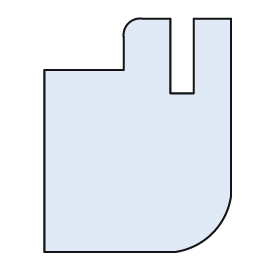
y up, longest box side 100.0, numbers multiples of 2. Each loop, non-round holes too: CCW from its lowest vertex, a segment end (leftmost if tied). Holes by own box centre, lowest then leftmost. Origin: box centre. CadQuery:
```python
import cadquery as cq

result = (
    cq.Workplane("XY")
    .moveTo(-40.0, -50.0)
    .lineTo(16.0, -50.0)
    .threePointArc((32.0, -42.0), (40.0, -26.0))
    .lineTo(40.0, 50.0)
    .lineTo(24.0, 50.0)
    .lineTo(24.0, 18.0)
    .lineTo(14.0, 18.0)
    .lineTo(14.0, 50.0)
    .lineTo(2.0, 50.0)
    .threePointArc((-4.0, 48.0), (-6.0, 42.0))
    .lineTo(-6.0, 28.0)
    .lineTo(-40.0, 28.0)
    .close()
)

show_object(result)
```